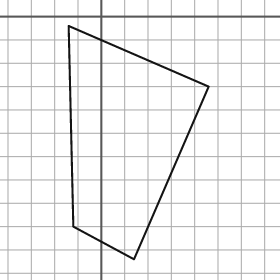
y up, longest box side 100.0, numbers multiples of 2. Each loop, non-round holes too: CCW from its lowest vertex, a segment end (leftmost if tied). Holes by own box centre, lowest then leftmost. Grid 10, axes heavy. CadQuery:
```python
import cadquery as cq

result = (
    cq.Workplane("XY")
    .moveTo(14.0, -104.0)
    .lineTo(46.0, -30.0)
    .lineTo(-14.0, -4.0)
    .lineTo(-12.0, -90.0)
    .close()
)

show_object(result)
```